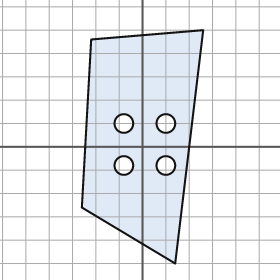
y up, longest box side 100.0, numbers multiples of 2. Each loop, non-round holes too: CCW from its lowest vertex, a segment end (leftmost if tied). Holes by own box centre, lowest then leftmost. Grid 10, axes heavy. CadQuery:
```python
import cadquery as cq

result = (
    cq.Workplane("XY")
    .moveTo(14.0, -50.0)
    .lineTo(26.0, 50.0)
    .lineTo(-22.0, 46.0)
    .lineTo(-26.0, -26.0)
    .close()
    .moveTo(-8.0, -8.0)
    .circle(4.0)
    .moveTo(10.0, -8.0)
    .circle(4.0)
    .moveTo(-8.0, 10.0)
    .circle(4.0)
    .moveTo(10.0, 10.0)
    .circle(4.0)
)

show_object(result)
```